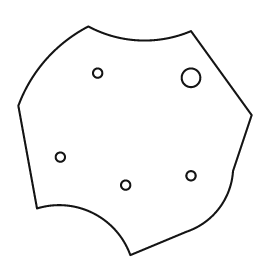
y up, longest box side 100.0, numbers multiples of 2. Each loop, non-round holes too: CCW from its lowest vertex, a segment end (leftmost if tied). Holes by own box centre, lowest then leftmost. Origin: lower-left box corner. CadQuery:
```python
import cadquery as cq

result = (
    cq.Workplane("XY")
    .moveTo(48.0, 0.0)
    .lineTo(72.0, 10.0)
    .threePointArc((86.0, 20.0), (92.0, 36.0))
    .lineTo(100.0, 60.0)
    .lineTo(74.0, 96.0)
    .threePointArc((52.0, 92.0), (30.0, 98.0))
    .threePointArc((12.0, 84.0), (0.0, 64.0))
    .lineTo(8.0, 20.0)
    .threePointArc((32.0, 18.0), (48.0, 0.0))
    .close()
    .moveTo(46.0, 30.0)
    .circle(2.0)
    .moveTo(74.0, 34.0)
    .circle(2.0)
    .moveTo(18.0, 42.0)
    .circle(2.0)
    .moveTo(74.0, 76.0)
    .circle(4.0)
    .moveTo(34.0, 78.0)
    .circle(2.0)
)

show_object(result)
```